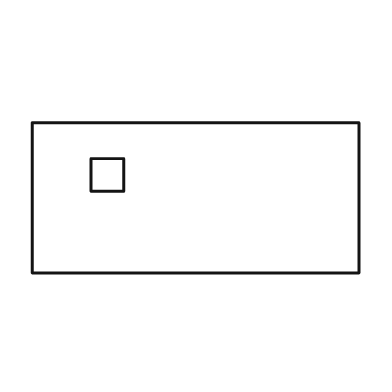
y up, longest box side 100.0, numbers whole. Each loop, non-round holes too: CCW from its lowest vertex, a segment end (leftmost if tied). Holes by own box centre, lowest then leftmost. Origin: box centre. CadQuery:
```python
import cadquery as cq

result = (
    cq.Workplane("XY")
    .moveTo(-50.0, -23.0)
    .lineTo(50.0, -23.0)
    .lineTo(50.0, 23.0)
    .lineTo(-50.0, 23.0)
    .close()
    .moveTo(-32.0, 2.0)
    .lineTo(-22.0, 2.0)
    .lineTo(-22.0, 12.0)
    .lineTo(-32.0, 12.0)
    .close()
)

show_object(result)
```